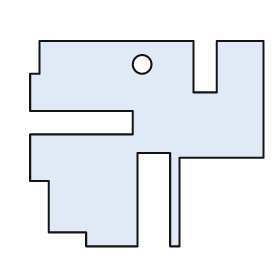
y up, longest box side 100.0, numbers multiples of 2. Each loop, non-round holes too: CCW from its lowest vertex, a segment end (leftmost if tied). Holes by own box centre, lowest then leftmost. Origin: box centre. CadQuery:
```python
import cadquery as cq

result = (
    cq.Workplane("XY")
    .moveTo(-26.0, -44.0)
    .lineTo(-4.0, -44.0)
    .lineTo(-4.0, -4.0)
    .lineTo(10.0, -4.0)
    .lineTo(10.0, -44.0)
    .lineTo(14.0, -44.0)
    .lineTo(14.0, -6.0)
    .lineTo(50.0, -6.0)
    .lineTo(50.0, 44.0)
    .lineTo(30.0, 44.0)
    .lineTo(30.0, 22.0)
    .lineTo(20.0, 22.0)
    .lineTo(20.0, 44.0)
    .lineTo(-46.0, 44.0)
    .lineTo(-46.0, 30.0)
    .lineTo(-50.0, 30.0)
    .lineTo(-50.0, 14.0)
    .lineTo(-6.0, 14.0)
    .lineTo(-6.0, 4.0)
    .lineTo(-50.0, 4.0)
    .lineTo(-50.0, -16.0)
    .lineTo(-42.0, -16.0)
    .lineTo(-42.0, -38.0)
    .lineTo(-26.0, -38.0)
    .close()
    .moveTo(-2.0, 34.0)
    .circle(4.0)
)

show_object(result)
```